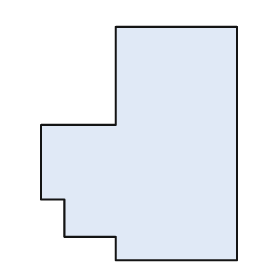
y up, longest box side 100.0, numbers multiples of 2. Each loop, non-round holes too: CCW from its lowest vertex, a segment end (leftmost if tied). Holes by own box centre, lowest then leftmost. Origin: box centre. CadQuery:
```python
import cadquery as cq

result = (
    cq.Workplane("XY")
    .moveTo(-10.0, -50.0)
    .lineTo(42.0, -50.0)
    .lineTo(42.0, 50.0)
    .lineTo(-10.0, 50.0)
    .lineTo(-10.0, 8.0)
    .lineTo(-42.0, 8.0)
    .lineTo(-42.0, -24.0)
    .lineTo(-32.0, -24.0)
    .lineTo(-32.0, -40.0)
    .lineTo(-10.0, -40.0)
    .close()
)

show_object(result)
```